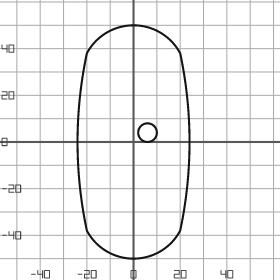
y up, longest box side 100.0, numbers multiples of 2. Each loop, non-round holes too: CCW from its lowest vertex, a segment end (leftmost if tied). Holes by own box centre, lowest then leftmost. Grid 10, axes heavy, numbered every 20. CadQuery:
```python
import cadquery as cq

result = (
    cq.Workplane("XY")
    .moveTo(-20.0, -38.0)
    .threePointArc((0.0, -50.0), (20.0, -38.0))
    .threePointArc((24.0, 0.0), (20.0, 38.0))
    .threePointArc((0.0, 50.0), (-20.0, 38.0))
    .threePointArc((-24.0, 0.0), (-20.0, -38.0))
    .close()
    .moveTo(6.0, 4.0)
    .circle(4.0)
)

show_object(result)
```